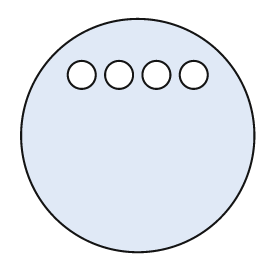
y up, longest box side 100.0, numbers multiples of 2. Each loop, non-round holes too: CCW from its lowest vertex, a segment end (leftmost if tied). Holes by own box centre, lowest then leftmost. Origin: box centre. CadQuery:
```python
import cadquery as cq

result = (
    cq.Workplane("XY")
    .moveTo(0.0, 0.0)
    .circle(50.0)
    .moveTo(-24.0, 26.0)
    .circle(6.0)
    .moveTo(-8.0, 26.0)
    .circle(6.0)
    .moveTo(8.0, 26.0)
    .circle(6.0)
    .moveTo(24.0, 26.0)
    .circle(6.0)
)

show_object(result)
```